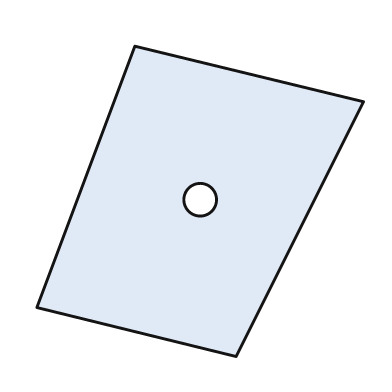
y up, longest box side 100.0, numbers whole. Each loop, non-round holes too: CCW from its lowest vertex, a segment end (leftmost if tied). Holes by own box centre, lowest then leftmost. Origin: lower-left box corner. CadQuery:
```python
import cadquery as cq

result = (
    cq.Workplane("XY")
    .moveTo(61.0, 0.0)
    .lineTo(100.0, 78.0)
    .lineTo(30.0, 95.0)
    .lineTo(0.0, 15.0)
    .close()
    .moveTo(50.0, 48.0)
    .circle(5.0)
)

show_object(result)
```